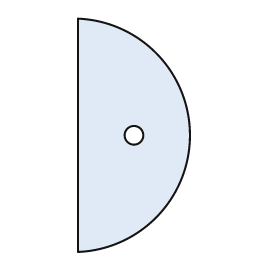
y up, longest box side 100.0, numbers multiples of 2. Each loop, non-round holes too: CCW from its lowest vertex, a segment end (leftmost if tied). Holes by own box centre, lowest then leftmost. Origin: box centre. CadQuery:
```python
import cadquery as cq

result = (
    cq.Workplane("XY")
    .moveTo(-24.0, -50.0)
    .threePointArc((24.0, 0.0), (-24.0, 50.0))
    .close()
    .moveTo(0.0, 0.0)
    .circle(4.0)
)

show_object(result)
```